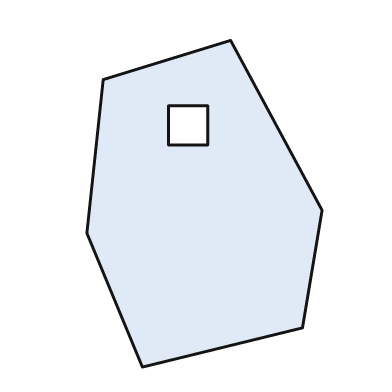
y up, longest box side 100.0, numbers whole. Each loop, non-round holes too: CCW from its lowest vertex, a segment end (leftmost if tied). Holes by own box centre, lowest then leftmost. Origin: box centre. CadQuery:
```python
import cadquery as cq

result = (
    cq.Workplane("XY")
    .moveTo(-19.0, -50.0)
    .lineTo(30.0, -38.0)
    .lineTo(36.0, -2.0)
    .lineTo(8.0, 50.0)
    .lineTo(-31.0, 38.0)
    .lineTo(-36.0, -9.0)
    .close()
    .moveTo(-11.0, 18.0)
    .lineTo(1.0, 18.0)
    .lineTo(1.0, 30.0)
    .lineTo(-11.0, 30.0)
    .close()
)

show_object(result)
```